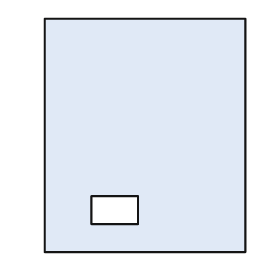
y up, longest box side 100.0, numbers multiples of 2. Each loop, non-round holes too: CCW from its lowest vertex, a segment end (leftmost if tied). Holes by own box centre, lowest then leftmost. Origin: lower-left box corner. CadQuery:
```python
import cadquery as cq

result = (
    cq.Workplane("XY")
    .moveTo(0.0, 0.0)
    .lineTo(86.0, 0.0)
    .lineTo(86.0, 100.0)
    .lineTo(0.0, 100.0)
    .close()
    .moveTo(20.0, 12.0)
    .lineTo(40.0, 12.0)
    .lineTo(40.0, 24.0)
    .lineTo(20.0, 24.0)
    .close()
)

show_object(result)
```